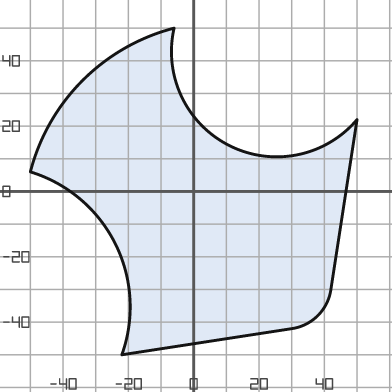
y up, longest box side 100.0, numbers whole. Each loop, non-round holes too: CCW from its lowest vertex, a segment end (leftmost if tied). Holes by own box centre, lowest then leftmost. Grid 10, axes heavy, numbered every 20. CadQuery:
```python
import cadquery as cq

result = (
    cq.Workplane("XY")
    .moveTo(-22.0, -50.0)
    .lineTo(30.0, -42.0)
    .threePointArc((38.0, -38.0), (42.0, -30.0))
    .lineTo(50.0, 22.0)
    .threePointArc((11.0, 14.0), (-6.0, 50.0))
    .threePointArc((-34.0, 34.0), (-50.0, 6.0))
    .threePointArc((-24.0, -16.0), (-22.0, -50.0))
    .close()
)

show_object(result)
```